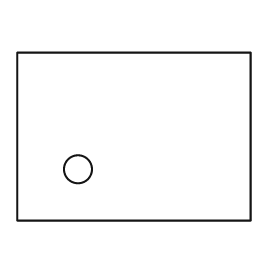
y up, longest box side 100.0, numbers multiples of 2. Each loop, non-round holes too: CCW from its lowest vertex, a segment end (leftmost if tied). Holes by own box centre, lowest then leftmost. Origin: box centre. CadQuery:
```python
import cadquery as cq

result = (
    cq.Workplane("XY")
    .moveTo(-50.0, -36.0)
    .lineTo(50.0, -36.0)
    .lineTo(50.0, 36.0)
    .lineTo(-50.0, 36.0)
    .close()
    .moveTo(-24.0, -14.0)
    .circle(6.0)
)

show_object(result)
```